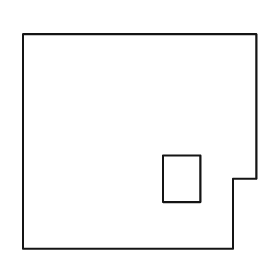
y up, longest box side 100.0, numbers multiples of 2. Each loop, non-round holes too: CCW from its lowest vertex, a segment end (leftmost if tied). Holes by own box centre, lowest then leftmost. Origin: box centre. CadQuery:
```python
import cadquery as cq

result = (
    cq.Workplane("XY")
    .moveTo(-50.0, -46.0)
    .lineTo(40.0, -46.0)
    .lineTo(40.0, -16.0)
    .lineTo(50.0, -16.0)
    .lineTo(50.0, 46.0)
    .lineTo(-50.0, 46.0)
    .close()
    .moveTo(10.0, -26.0)
    .lineTo(26.0, -26.0)
    .lineTo(26.0, -6.0)
    .lineTo(10.0, -6.0)
    .close()
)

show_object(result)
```